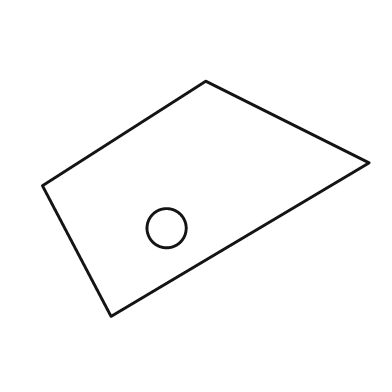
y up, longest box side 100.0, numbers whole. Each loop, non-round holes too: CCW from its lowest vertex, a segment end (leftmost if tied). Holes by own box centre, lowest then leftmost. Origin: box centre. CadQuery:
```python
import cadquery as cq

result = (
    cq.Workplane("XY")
    .moveTo(-29.0, -36.0)
    .lineTo(50.0, 11.0)
    .lineTo(0.0, 36.0)
    .lineTo(-50.0, 4.0)
    .close()
    .moveTo(-12.0, -9.0)
    .circle(6.0)
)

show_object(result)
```